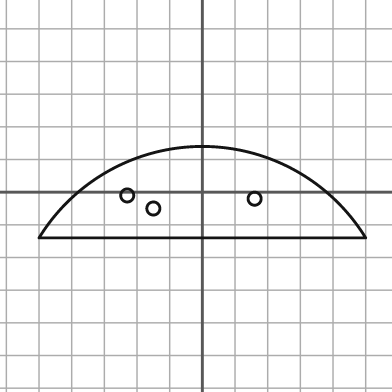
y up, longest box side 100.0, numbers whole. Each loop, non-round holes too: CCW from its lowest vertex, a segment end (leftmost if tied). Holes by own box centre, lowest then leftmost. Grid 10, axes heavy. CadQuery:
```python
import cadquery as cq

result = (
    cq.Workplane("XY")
    .moveTo(-50.0, -14.0)
    .lineTo(50.0, -14.0)
    .threePointArc((0.0, 14.0), (-50.0, -14.0))
    .close()
    .moveTo(-15.0, -5.0)
    .circle(2.0)
    .moveTo(16.0, -2.0)
    .circle(2.0)
    .moveTo(-23.0, -1.0)
    .circle(2.0)
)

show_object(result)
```